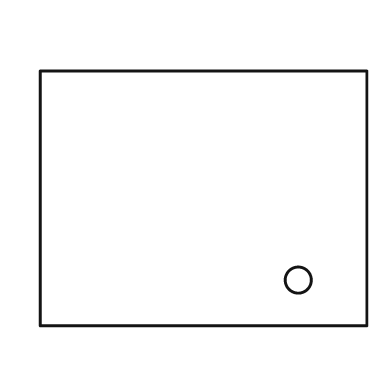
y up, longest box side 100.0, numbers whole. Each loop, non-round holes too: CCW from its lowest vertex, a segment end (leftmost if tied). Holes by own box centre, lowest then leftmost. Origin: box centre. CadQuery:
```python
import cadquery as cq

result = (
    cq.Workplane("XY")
    .moveTo(-50.0, -39.0)
    .lineTo(50.0, -39.0)
    .lineTo(50.0, 39.0)
    .lineTo(-50.0, 39.0)
    .close()
    .moveTo(29.0, -25.0)
    .circle(4.0)
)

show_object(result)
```